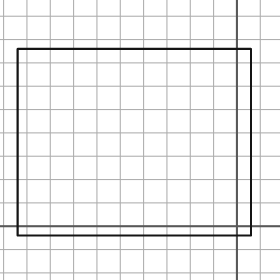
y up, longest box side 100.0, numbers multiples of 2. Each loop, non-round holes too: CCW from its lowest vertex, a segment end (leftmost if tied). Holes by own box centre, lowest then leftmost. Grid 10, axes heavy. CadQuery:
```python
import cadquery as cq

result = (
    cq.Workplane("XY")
    .moveTo(-94.0, -4.0)
    .lineTo(6.0, -4.0)
    .lineTo(6.0, 76.0)
    .lineTo(-94.0, 76.0)
    .close()
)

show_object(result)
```